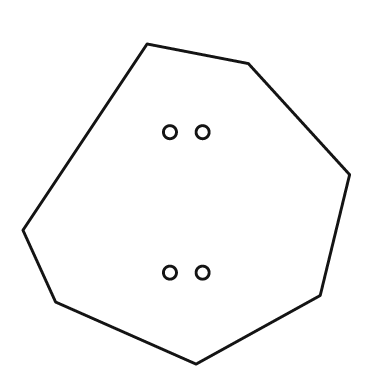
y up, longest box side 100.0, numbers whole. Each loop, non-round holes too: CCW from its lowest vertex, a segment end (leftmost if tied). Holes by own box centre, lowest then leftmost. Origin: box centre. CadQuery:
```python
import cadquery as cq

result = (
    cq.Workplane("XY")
    .moveTo(3.0, -49.0)
    .lineTo(41.0, -28.0)
    .lineTo(50.0, 9.0)
    .lineTo(19.0, 43.0)
    .lineTo(-12.0, 49.0)
    .lineTo(-50.0, -8.0)
    .lineTo(-40.0, -30.0)
    .close()
    .moveTo(-5.0, -21.0)
    .circle(2.0)
    .moveTo(5.0, -21.0)
    .circle(2.0)
    .moveTo(-5.0, 22.0)
    .circle(2.0)
    .moveTo(5.0, 22.0)
    .circle(2.0)
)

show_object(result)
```